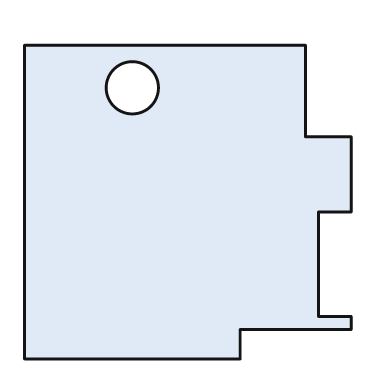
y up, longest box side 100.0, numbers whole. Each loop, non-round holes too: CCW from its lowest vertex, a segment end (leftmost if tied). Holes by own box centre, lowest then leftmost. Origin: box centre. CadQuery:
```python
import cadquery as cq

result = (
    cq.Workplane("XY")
    .moveTo(-50.0, -48.0)
    .lineTo(16.0, -48.0)
    .lineTo(16.0, -39.0)
    .lineTo(50.0, -39.0)
    .lineTo(50.0, -35.0)
    .lineTo(40.0, -35.0)
    .lineTo(40.0, -3.0)
    .lineTo(50.0, -3.0)
    .lineTo(50.0, 20.0)
    .lineTo(36.0, 20.0)
    .lineTo(36.0, 48.0)
    .lineTo(-50.0, 48.0)
    .close()
    .moveTo(-17.0, 35.0)
    .circle(8.0)
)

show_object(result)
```